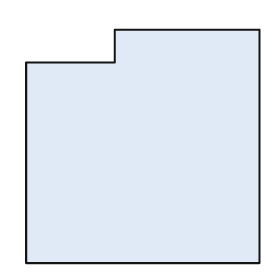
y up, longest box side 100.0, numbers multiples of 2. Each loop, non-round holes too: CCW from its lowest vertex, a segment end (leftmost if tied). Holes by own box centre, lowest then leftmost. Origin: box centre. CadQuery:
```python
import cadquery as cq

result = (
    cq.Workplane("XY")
    .moveTo(-50.0, -50.0)
    .lineTo(50.0, -50.0)
    .lineTo(50.0, 50.0)
    .lineTo(-12.0, 50.0)
    .lineTo(-12.0, 36.0)
    .lineTo(-50.0, 36.0)
    .close()
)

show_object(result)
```